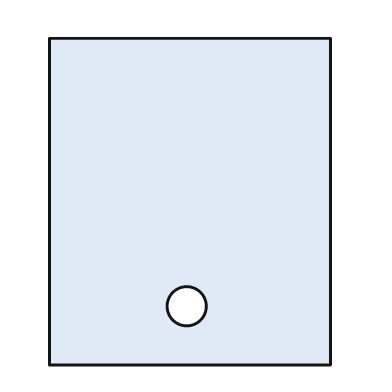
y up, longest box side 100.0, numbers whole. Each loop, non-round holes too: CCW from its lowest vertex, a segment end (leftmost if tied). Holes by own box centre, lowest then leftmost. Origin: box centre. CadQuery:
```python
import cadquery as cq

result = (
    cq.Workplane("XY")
    .moveTo(-43.0, -50.0)
    .lineTo(43.0, -50.0)
    .lineTo(43.0, 50.0)
    .lineTo(-43.0, 50.0)
    .close()
    .moveTo(-1.0, -32.0)
    .circle(6.0)
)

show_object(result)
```